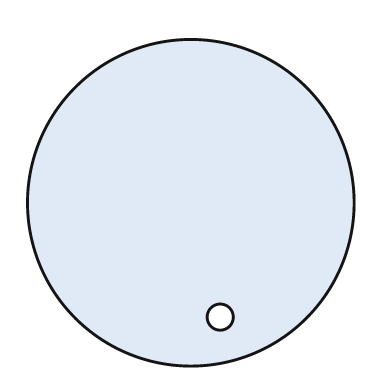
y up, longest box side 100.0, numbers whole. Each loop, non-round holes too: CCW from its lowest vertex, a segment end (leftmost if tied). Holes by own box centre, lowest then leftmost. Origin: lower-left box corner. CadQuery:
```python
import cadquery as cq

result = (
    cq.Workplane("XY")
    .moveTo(50.0, 50.0)
    .circle(50.0)
    .moveTo(59.0, 15.0)
    .circle(4.0)
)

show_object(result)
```